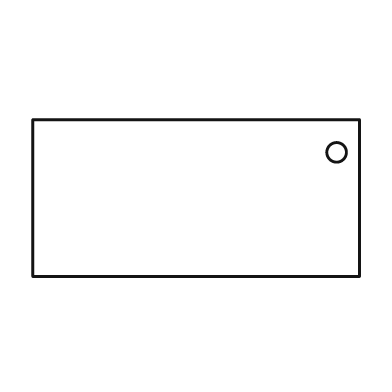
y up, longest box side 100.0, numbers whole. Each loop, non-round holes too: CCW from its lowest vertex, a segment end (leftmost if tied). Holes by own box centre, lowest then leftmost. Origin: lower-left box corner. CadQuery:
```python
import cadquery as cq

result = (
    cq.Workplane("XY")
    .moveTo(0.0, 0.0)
    .lineTo(100.0, 0.0)
    .lineTo(100.0, 48.0)
    .lineTo(0.0, 48.0)
    .close()
    .moveTo(93.0, 38.0)
    .circle(3.0)
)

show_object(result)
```